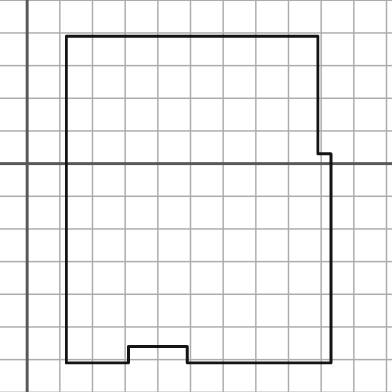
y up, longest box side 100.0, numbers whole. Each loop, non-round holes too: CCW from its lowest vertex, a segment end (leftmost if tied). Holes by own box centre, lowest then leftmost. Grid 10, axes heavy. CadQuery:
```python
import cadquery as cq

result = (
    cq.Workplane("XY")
    .moveTo(12.0, -61.0)
    .lineTo(31.0, -61.0)
    .lineTo(31.0, -56.0)
    .lineTo(49.0, -56.0)
    .lineTo(49.0, -61.0)
    .lineTo(93.0, -61.0)
    .lineTo(93.0, 3.0)
    .lineTo(89.0, 3.0)
    .lineTo(89.0, 39.0)
    .lineTo(12.0, 39.0)
    .close()
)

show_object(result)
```